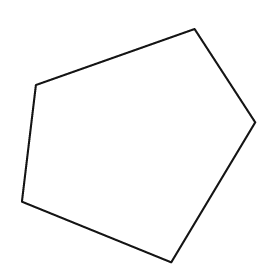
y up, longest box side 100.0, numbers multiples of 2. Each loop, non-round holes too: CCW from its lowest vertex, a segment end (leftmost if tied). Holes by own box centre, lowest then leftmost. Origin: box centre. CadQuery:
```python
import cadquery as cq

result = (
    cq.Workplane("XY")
    .moveTo(14.0, -50.0)
    .lineTo(50.0, 10.0)
    .lineTo(24.0, 50.0)
    .lineTo(-44.0, 26.0)
    .lineTo(-50.0, -24.0)
    .close()
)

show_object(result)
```